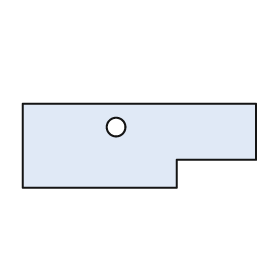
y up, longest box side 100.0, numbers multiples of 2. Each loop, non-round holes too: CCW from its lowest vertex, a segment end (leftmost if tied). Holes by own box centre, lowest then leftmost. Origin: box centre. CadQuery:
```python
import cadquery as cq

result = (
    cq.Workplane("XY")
    .moveTo(-50.0, -18.0)
    .lineTo(16.0, -18.0)
    .lineTo(16.0, -6.0)
    .lineTo(50.0, -6.0)
    .lineTo(50.0, 18.0)
    .lineTo(-50.0, 18.0)
    .close()
    .moveTo(-10.0, 8.0)
    .circle(4.0)
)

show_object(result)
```